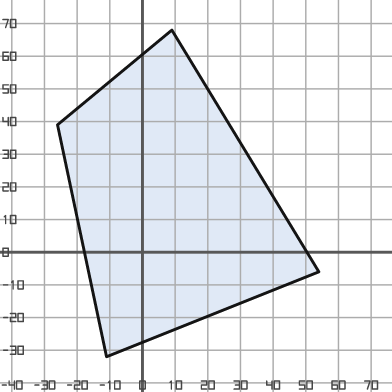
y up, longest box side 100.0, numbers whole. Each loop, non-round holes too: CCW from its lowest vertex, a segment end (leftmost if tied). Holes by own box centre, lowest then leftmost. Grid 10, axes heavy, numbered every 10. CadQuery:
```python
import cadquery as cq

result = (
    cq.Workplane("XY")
    .moveTo(-11.0, -32.0)
    .lineTo(54.0, -6.0)
    .lineTo(9.0, 68.0)
    .lineTo(-26.0, 39.0)
    .close()
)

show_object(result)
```